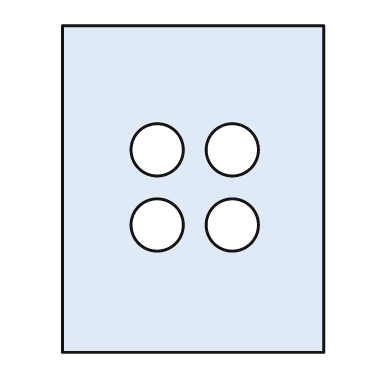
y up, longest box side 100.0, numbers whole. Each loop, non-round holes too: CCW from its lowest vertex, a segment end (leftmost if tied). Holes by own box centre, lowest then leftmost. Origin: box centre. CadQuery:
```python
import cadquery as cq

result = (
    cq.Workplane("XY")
    .moveTo(-40.0, -50.0)
    .lineTo(40.0, -50.0)
    .lineTo(40.0, 50.0)
    .lineTo(-40.0, 50.0)
    .close()
    .moveTo(-11.0, -11.0)
    .circle(8.0)
    .moveTo(12.0, -11.0)
    .circle(8.0)
    .moveTo(-11.0, 12.0)
    .circle(8.0)
    .moveTo(12.0, 12.0)
    .circle(8.0)
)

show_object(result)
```